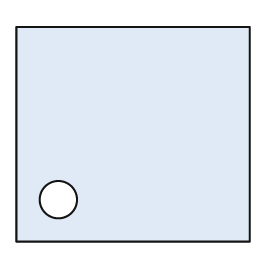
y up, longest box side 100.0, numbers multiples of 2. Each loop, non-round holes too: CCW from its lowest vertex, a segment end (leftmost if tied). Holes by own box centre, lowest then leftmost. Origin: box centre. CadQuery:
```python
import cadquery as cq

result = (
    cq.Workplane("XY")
    .moveTo(-50.0, -46.0)
    .lineTo(50.0, -46.0)
    .lineTo(50.0, 46.0)
    .lineTo(-50.0, 46.0)
    .close()
    .moveTo(-32.0, -28.0)
    .circle(8.0)
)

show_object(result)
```